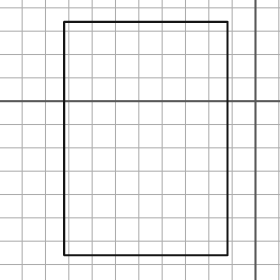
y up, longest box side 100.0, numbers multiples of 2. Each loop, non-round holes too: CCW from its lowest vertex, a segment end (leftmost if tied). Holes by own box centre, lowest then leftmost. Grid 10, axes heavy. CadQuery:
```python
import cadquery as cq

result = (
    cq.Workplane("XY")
    .moveTo(-82.0, -66.0)
    .lineTo(-12.0, -66.0)
    .lineTo(-12.0, 34.0)
    .lineTo(-82.0, 34.0)
    .close()
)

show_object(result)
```